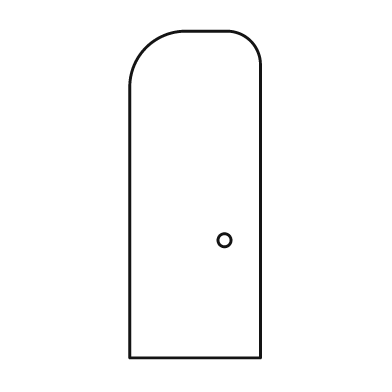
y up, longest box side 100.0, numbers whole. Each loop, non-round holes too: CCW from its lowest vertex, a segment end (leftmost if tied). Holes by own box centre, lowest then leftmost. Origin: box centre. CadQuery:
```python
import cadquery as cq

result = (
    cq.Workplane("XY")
    .moveTo(-20.0, -50.0)
    .lineTo(20.0, -50.0)
    .lineTo(20.0, 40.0)
    .threePointArc((17.0, 47.0), (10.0, 50.0))
    .lineTo(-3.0, 50.0)
    .threePointArc((-15.0, 45.0), (-20.0, 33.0))
    .close()
    .moveTo(9.0, -14.0)
    .circle(2.0)
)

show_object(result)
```